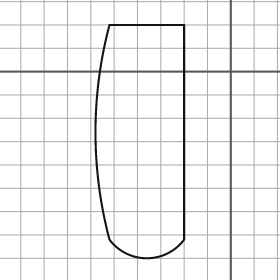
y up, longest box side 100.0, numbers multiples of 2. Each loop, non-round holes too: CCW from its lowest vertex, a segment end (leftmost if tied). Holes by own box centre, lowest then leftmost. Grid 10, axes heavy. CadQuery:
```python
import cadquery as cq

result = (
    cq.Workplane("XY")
    .moveTo(-52.0, -72.0)
    .threePointArc((-36.0, -80.0), (-20.0, -72.0))
    .lineTo(-20.0, 20.0)
    .lineTo(-52.0, 20.0)
    .threePointArc((-58.0, -26.0), (-52.0, -72.0))
    .close()
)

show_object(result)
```